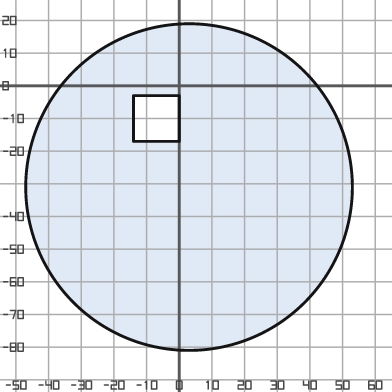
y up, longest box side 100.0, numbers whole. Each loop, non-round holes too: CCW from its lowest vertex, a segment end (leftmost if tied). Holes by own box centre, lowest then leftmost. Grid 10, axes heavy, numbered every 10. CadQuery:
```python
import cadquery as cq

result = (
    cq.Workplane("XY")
    .moveTo(3.0, -31.0)
    .circle(50.0)
    .moveTo(-14.0, -17.0)
    .lineTo(0.0, -17.0)
    .lineTo(0.0, -3.0)
    .lineTo(-14.0, -3.0)
    .close()
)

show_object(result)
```